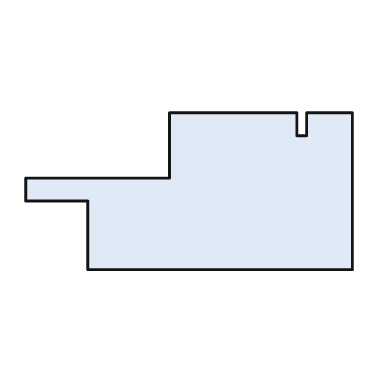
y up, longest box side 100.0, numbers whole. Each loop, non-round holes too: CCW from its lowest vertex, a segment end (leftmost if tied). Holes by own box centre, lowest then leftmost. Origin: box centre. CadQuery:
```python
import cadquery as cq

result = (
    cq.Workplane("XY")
    .moveTo(-31.0, -24.0)
    .lineTo(50.0, -24.0)
    .lineTo(50.0, 24.0)
    .lineTo(36.0, 24.0)
    .lineTo(36.0, 17.0)
    .lineTo(33.0, 17.0)
    .lineTo(33.0, 24.0)
    .lineTo(-6.0, 24.0)
    .lineTo(-6.0, 4.0)
    .lineTo(-50.0, 4.0)
    .lineTo(-50.0, -3.0)
    .lineTo(-31.0, -3.0)
    .close()
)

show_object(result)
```